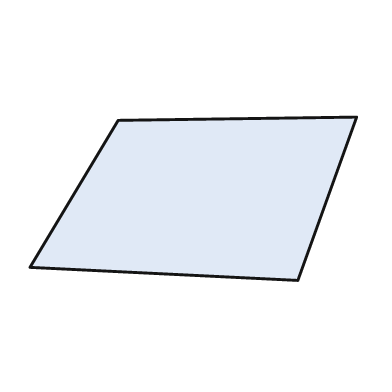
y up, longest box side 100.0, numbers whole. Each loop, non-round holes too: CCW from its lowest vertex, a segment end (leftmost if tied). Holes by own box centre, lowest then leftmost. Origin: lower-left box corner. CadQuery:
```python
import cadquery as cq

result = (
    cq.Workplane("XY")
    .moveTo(82.0, 0.0)
    .lineTo(100.0, 50.0)
    .lineTo(27.0, 49.0)
    .lineTo(0.0, 4.0)
    .close()
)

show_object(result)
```